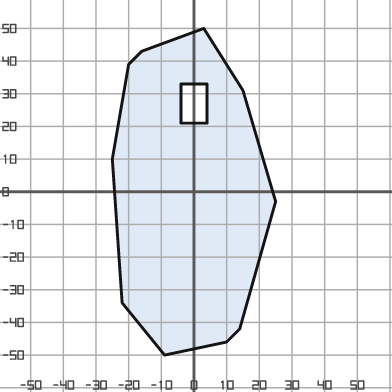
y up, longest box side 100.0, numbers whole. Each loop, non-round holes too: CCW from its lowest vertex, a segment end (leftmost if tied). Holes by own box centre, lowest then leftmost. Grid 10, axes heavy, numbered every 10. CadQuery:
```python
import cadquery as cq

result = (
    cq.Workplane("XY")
    .moveTo(-9.0, -50.0)
    .lineTo(10.0, -46.0)
    .lineTo(14.0, -42.0)
    .lineTo(25.0, -3.0)
    .lineTo(15.0, 31.0)
    .lineTo(3.0, 50.0)
    .lineTo(-16.0, 43.0)
    .lineTo(-20.0, 39.0)
    .lineTo(-25.0, 10.0)
    .lineTo(-22.0, -34.0)
    .close()
    .moveTo(-4.0, 21.0)
    .lineTo(4.0, 21.0)
    .lineTo(4.0, 33.0)
    .lineTo(-4.0, 33.0)
    .close()
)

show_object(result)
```